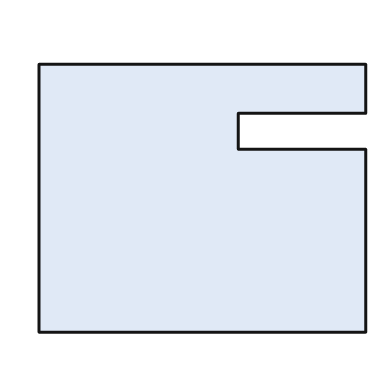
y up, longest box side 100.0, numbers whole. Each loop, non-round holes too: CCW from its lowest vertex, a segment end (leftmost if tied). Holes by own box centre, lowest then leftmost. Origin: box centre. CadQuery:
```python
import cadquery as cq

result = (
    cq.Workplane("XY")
    .moveTo(-50.0, -41.0)
    .lineTo(50.0, -41.0)
    .lineTo(50.0, 15.0)
    .lineTo(11.0, 15.0)
    .lineTo(11.0, 26.0)
    .lineTo(50.0, 26.0)
    .lineTo(50.0, 41.0)
    .lineTo(-50.0, 41.0)
    .close()
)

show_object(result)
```